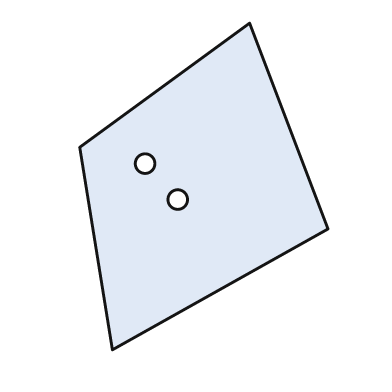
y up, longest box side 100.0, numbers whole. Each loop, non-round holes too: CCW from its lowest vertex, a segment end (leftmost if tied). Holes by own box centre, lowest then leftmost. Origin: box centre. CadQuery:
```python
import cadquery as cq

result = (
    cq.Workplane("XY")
    .moveTo(-28.0, -50.0)
    .lineTo(38.0, -13.0)
    .lineTo(14.0, 50.0)
    .lineTo(-38.0, 12.0)
    .close()
    .moveTo(-8.0, -4.0)
    .circle(3.0)
    .moveTo(-18.0, 7.0)
    .circle(3.0)
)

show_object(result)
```